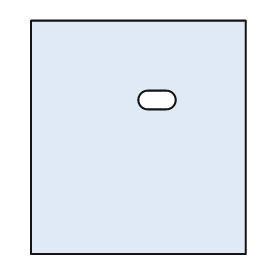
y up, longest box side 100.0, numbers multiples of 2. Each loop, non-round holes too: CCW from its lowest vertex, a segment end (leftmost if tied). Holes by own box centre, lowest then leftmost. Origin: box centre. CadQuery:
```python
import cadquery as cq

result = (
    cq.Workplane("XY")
    .moveTo(-46.0, -50.0)
    .lineTo(46.0, -50.0)
    .lineTo(46.0, 50.0)
    .lineTo(-46.0, 50.0)
    .close()
    .moveTo(4.0, 12.0)
    .lineTo(12.0, 12.0)
    .threePointArc((16.0, 16.0), (12.0, 20.0))
    .lineTo(4.0, 20.0)
    .threePointArc((0.0, 16.0), (4.0, 12.0))
    .close()
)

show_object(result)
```